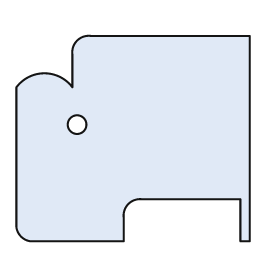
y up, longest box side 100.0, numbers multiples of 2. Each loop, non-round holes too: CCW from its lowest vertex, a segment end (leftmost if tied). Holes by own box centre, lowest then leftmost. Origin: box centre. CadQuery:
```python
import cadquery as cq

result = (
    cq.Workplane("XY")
    .moveTo(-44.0, -44.0)
    .lineTo(-4.0, -44.0)
    .lineTo(-4.0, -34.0)
    .threePointArc((-2.0, -28.0), (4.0, -26.0))
    .lineTo(46.0, -26.0)
    .lineTo(46.0, -44.0)
    .lineTo(50.0, -44.0)
    .lineTo(50.0, 44.0)
    .lineTo(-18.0, 44.0)
    .threePointArc((-24.0, 42.0), (-26.0, 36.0))
    .lineTo(-26.0, 22.0)
    .threePointArc((-38.0, 28.0), (-50.0, 22.0))
    .lineTo(-50.0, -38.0)
    .threePointArc((-48.0, -42.0), (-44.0, -44.0))
    .close()
    .moveTo(-24.0, 6.0)
    .circle(4.0)
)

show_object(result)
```